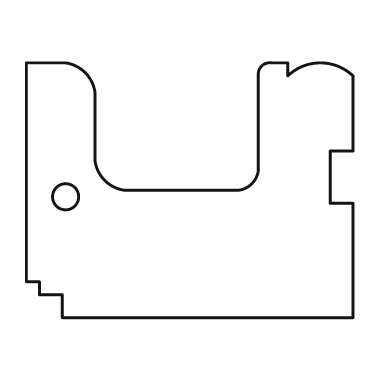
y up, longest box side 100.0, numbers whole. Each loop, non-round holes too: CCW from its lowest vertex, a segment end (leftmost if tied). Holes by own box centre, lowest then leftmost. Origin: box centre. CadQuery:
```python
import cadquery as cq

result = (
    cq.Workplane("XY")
    .moveTo(-39.0, -39.0)
    .lineTo(50.0, -39.0)
    .lineTo(50.0, -4.0)
    .lineTo(43.0, -4.0)
    .lineTo(43.0, 12.0)
    .lineTo(50.0, 12.0)
    .lineTo(50.0, 35.0)
    .threePointArc((40.0, 39.0), (30.0, 35.0))
    .lineTo(30.0, 39.0)
    .lineTo(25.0, 39.0)
    .threePointArc((22.0, 38.0), (21.0, 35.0))
    .lineTo(21.0, 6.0)
    .threePointArc((19.0, 2.0), (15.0, 0.0))
    .lineTo(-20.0, 0.0)
    .threePointArc((-26.0, 3.0), (-29.0, 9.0))
    .lineTo(-29.0, 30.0)
    .threePointArc((-32.0, 36.0), (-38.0, 39.0))
    .lineTo(-50.0, 39.0)
    .lineTo(-50.0, -28.0)
    .lineTo(-46.0, -28.0)
    .lineTo(-46.0, -32.0)
    .lineTo(-39.0, -32.0)
    .close()
    .moveTo(-38.0, -2.0)
    .circle(4.0)
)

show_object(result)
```